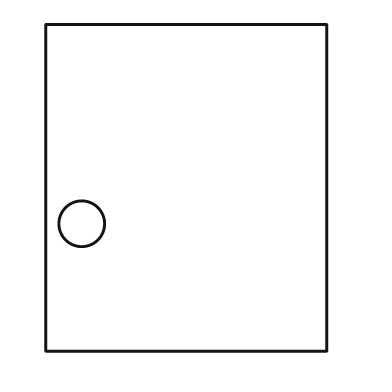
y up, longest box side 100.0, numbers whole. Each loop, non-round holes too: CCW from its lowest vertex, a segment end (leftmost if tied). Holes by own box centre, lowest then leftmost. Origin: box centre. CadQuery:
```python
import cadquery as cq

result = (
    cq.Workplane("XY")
    .moveTo(-43.0, -50.0)
    .lineTo(43.0, -50.0)
    .lineTo(43.0, 50.0)
    .lineTo(-43.0, 50.0)
    .close()
    .moveTo(-32.0, -11.0)
    .circle(7.0)
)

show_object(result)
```